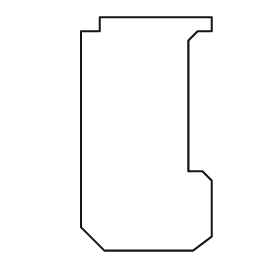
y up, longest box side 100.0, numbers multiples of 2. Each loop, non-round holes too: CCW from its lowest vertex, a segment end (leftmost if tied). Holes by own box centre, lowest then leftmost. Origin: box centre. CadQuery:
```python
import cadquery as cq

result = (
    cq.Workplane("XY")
    .moveTo(-18.0, -50.0)
    .lineTo(20.0, -50.0)
    .lineTo(28.0, -44.0)
    .lineTo(28.0, -20.0)
    .lineTo(24.0, -16.0)
    .lineTo(18.0, -16.0)
    .lineTo(18.0, 40.0)
    .lineTo(22.0, 44.0)
    .lineTo(28.0, 44.0)
    .lineTo(28.0, 50.0)
    .lineTo(-20.0, 50.0)
    .lineTo(-20.0, 44.0)
    .lineTo(-28.0, 44.0)
    .lineTo(-28.0, -40.0)
    .close()
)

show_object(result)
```